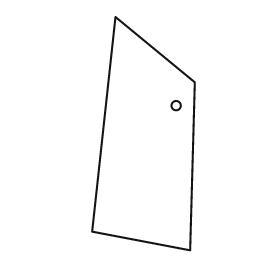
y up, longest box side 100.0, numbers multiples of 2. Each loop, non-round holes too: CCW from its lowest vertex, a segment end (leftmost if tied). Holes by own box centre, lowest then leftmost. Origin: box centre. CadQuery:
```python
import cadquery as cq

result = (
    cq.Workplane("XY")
    .moveTo(20.0, -50.0)
    .lineTo(22.0, 22.0)
    .lineTo(-12.0, 50.0)
    .lineTo(-22.0, -42.0)
    .close()
    .moveTo(14.0, 12.0)
    .circle(2.0)
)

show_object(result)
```